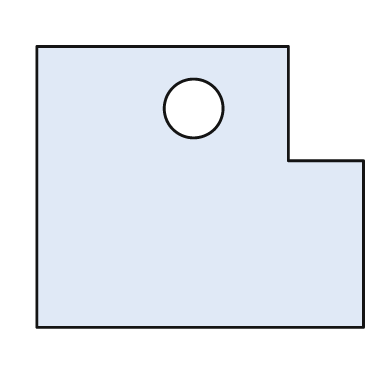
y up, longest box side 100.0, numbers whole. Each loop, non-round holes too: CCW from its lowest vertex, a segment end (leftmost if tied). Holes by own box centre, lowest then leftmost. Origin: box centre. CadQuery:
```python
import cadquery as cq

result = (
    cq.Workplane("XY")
    .moveTo(-50.0, -43.0)
    .lineTo(50.0, -43.0)
    .lineTo(50.0, 8.0)
    .lineTo(27.0, 8.0)
    .lineTo(27.0, 43.0)
    .lineTo(-50.0, 43.0)
    .close()
    .moveTo(-2.0, 24.0)
    .circle(9.0)
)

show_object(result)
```